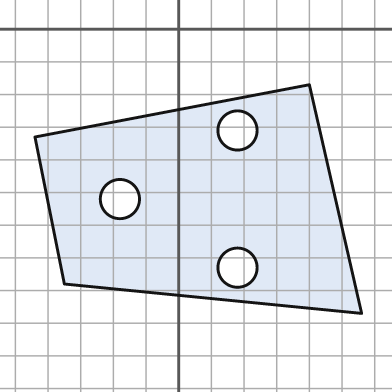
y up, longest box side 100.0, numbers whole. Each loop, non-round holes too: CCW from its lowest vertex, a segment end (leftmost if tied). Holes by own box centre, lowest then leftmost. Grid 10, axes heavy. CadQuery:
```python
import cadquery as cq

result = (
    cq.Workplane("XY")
    .moveTo(56.0, -87.0)
    .lineTo(40.0, -17.0)
    .lineTo(-44.0, -33.0)
    .lineTo(-35.0, -78.0)
    .close()
    .moveTo(18.0, -73.0)
    .circle(6.0)
    .moveTo(-18.0, -52.0)
    .circle(6.0)
    .moveTo(18.0, -31.0)
    .circle(6.0)
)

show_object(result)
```